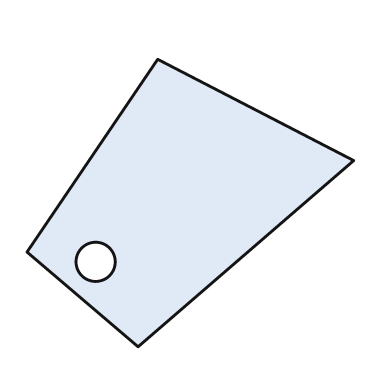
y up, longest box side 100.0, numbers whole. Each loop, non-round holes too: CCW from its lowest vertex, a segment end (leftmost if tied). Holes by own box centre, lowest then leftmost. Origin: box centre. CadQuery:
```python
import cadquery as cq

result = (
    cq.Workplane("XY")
    .moveTo(-16.0, -44.0)
    .lineTo(50.0, 13.0)
    .lineTo(-10.0, 44.0)
    .lineTo(-50.0, -15.0)
    .close()
    .moveTo(-29.0, -18.0)
    .circle(6.0)
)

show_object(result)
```